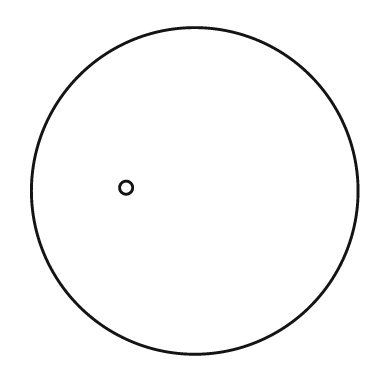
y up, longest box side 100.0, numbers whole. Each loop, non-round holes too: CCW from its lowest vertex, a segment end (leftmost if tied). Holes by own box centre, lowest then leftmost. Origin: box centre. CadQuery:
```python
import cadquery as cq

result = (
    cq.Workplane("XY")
    .moveTo(0.0, 0.0)
    .circle(50.0)
    .moveTo(-21.0, 1.0)
    .circle(2.0)
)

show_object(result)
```